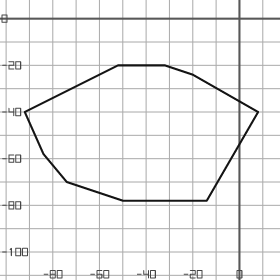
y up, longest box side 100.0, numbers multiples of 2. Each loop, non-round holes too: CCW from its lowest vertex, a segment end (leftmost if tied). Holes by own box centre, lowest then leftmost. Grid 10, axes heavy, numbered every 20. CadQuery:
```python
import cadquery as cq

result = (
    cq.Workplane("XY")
    .moveTo(-50.0, -78.0)
    .lineTo(-14.0, -78.0)
    .lineTo(8.0, -40.0)
    .lineTo(-20.0, -24.0)
    .lineTo(-32.0, -20.0)
    .lineTo(-52.0, -20.0)
    .lineTo(-92.0, -40.0)
    .lineTo(-84.0, -58.0)
    .lineTo(-74.0, -70.0)
    .close()
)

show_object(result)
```